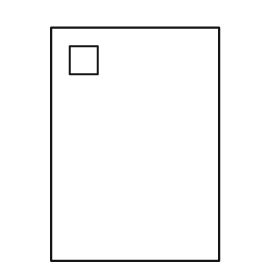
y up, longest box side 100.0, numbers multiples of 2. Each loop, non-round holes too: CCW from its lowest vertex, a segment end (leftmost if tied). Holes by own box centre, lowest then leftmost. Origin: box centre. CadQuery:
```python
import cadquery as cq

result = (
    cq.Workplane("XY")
    .moveTo(-36.0, -50.0)
    .lineTo(36.0, -50.0)
    .lineTo(36.0, 50.0)
    .lineTo(-36.0, 50.0)
    .close()
    .moveTo(-28.0, 30.0)
    .lineTo(-16.0, 30.0)
    .lineTo(-16.0, 42.0)
    .lineTo(-28.0, 42.0)
    .close()
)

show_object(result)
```